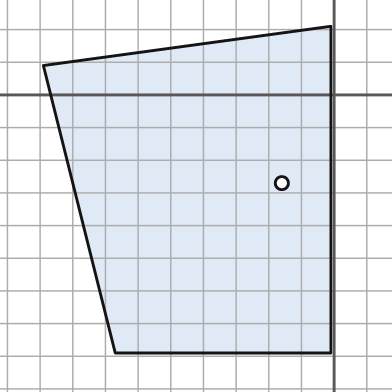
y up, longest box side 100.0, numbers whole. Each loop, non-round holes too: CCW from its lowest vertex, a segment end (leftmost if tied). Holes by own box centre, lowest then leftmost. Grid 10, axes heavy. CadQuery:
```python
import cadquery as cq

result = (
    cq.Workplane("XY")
    .moveTo(-67.0, -79.0)
    .lineTo(-1.0, -79.0)
    .lineTo(-1.0, 21.0)
    .lineTo(-89.0, 9.0)
    .close()
    .moveTo(-16.0, -27.0)
    .circle(2.0)
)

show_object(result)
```